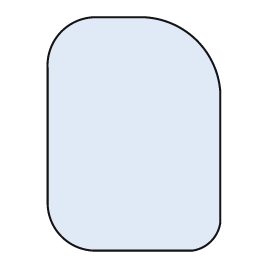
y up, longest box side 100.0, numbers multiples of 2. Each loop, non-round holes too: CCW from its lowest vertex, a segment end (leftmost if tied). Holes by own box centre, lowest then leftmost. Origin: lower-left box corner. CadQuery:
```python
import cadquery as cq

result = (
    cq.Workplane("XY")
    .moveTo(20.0, 0.0)
    .lineTo(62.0, 0.0)
    .threePointArc((70.0, 4.0), (74.0, 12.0))
    .lineTo(74.0, 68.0)
    .threePointArc((64.0, 90.0), (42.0, 100.0))
    .lineTo(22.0, 100.0)
    .threePointArc((6.0, 94.0), (0.0, 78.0))
    .lineTo(0.0, 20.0)
    .threePointArc((6.0, 6.0), (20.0, 0.0))
    .close()
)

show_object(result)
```